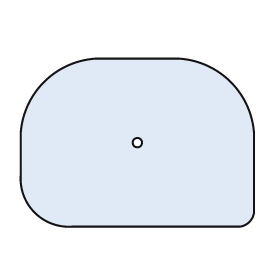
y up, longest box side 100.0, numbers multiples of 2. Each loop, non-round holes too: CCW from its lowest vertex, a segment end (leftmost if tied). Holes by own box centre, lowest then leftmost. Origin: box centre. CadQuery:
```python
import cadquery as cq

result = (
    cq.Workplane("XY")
    .moveTo(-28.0, -36.0)
    .lineTo(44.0, -36.0)
    .threePointArc((48.0, -34.0), (50.0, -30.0))
    .lineTo(50.0, 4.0)
    .threePointArc((40.0, 26.0), (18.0, 36.0))
    .lineTo(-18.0, 36.0)
    .threePointArc((-40.0, 26.0), (-50.0, 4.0))
    .lineTo(-50.0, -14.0)
    .threePointArc((-44.0, -30.0), (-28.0, -36.0))
    .close()
    .moveTo(0.0, 0.0)
    .circle(2.0)
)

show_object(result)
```